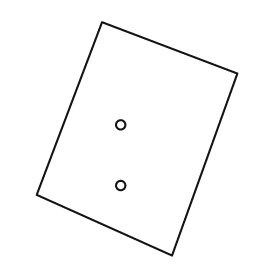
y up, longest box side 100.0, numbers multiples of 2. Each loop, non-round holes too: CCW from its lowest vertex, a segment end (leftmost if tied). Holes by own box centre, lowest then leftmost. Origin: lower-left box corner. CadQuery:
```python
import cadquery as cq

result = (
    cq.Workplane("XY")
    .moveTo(58.0, 0.0)
    .lineTo(86.0, 78.0)
    .lineTo(28.0, 100.0)
    .lineTo(0.0, 26.0)
    .close()
    .moveTo(36.0, 30.0)
    .circle(2.0)
    .moveTo(36.0, 56.0)
    .circle(2.0)
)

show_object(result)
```